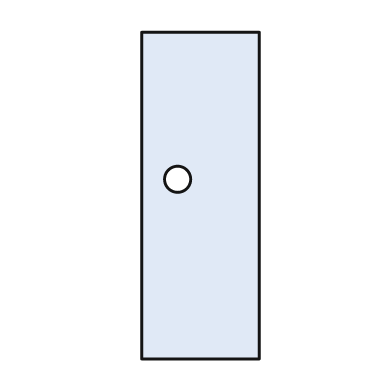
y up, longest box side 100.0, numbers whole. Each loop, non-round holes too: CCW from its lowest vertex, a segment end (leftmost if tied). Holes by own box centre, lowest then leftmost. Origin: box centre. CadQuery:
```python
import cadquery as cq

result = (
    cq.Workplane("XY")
    .moveTo(-18.0, -50.0)
    .lineTo(18.0, -50.0)
    .lineTo(18.0, 50.0)
    .lineTo(-18.0, 50.0)
    .close()
    .moveTo(-7.0, 5.0)
    .circle(4.0)
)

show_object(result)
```